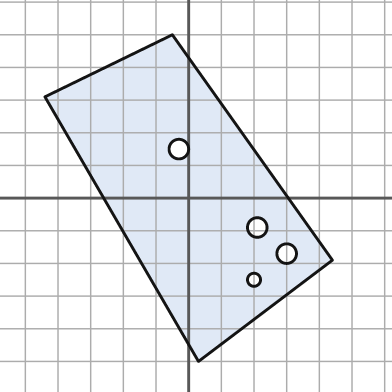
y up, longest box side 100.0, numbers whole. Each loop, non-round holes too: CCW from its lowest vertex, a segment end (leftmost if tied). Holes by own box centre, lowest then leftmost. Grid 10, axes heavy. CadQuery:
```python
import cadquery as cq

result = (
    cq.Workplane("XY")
    .moveTo(3.0, -50.0)
    .lineTo(44.0, -19.0)
    .lineTo(-5.0, 50.0)
    .lineTo(-44.0, 31.0)
    .close()
    .moveTo(20.0, -25.0)
    .circle(2.0)
    .moveTo(30.0, -17.0)
    .circle(3.0)
    .moveTo(21.0, -9.0)
    .circle(3.0)
    .moveTo(-3.0, 15.0)
    .circle(3.0)
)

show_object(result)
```